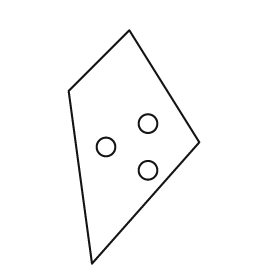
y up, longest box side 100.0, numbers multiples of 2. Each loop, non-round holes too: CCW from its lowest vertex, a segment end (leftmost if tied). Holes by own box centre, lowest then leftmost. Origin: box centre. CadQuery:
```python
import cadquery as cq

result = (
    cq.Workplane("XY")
    .moveTo(-18.0, -50.0)
    .lineTo(28.0, 2.0)
    .lineTo(-2.0, 50.0)
    .lineTo(-28.0, 24.0)
    .close()
    .moveTo(6.0, -10.0)
    .circle(4.0)
    .moveTo(-12.0, 0.0)
    .circle(4.0)
    .moveTo(6.0, 10.0)
    .circle(4.0)
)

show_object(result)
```